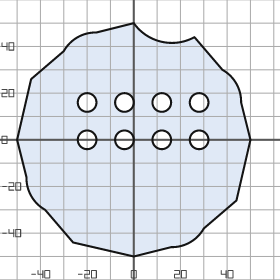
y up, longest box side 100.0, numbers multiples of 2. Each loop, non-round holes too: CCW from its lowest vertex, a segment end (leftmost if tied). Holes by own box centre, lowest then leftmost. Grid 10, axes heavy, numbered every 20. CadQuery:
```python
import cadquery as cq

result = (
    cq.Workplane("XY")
    .moveTo(0.0, -50.0)
    .lineTo(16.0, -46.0)
    .threePointArc((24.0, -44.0), (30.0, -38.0))
    .lineTo(44.0, -26.0)
    .lineTo(50.0, 0.0)
    .lineTo(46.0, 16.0)
    .threePointArc((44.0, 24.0), (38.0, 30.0))
    .lineTo(26.0, 44.0)
    .threePointArc((12.0, 42.0), (0.0, 50.0))
    .lineTo(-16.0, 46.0)
    .threePointArc((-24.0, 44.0), (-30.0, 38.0))
    .lineTo(-44.0, 26.0)
    .lineTo(-50.0, 0.0)
    .lineTo(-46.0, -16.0)
    .threePointArc((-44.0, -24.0), (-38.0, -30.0))
    .lineTo(-26.0, -44.0)
    .close()
    .moveTo(-20.0, 0.0)
    .circle(4.0)
    .moveTo(-4.0, 0.0)
    .circle(4.0)
    .moveTo(12.0, 0.0)
    .circle(4.0)
    .moveTo(28.0, 0.0)
    .circle(4.0)
    .moveTo(-20.0, 16.0)
    .circle(4.0)
    .moveTo(-4.0, 16.0)
    .circle(4.0)
    .moveTo(12.0, 16.0)
    .circle(4.0)
    .moveTo(28.0, 16.0)
    .circle(4.0)
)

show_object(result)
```